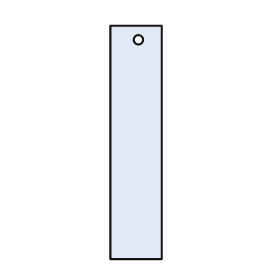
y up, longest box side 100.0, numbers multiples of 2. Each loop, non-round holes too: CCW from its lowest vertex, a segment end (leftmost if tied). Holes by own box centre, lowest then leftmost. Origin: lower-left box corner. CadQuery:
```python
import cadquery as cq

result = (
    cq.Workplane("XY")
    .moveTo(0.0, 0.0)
    .lineTo(22.0, 0.0)
    .lineTo(22.0, 100.0)
    .lineTo(0.0, 100.0)
    .close()
    .moveTo(12.0, 94.0)
    .circle(2.0)
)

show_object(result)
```